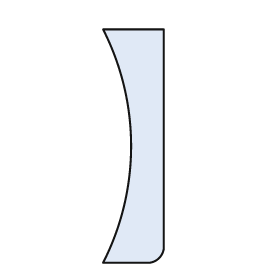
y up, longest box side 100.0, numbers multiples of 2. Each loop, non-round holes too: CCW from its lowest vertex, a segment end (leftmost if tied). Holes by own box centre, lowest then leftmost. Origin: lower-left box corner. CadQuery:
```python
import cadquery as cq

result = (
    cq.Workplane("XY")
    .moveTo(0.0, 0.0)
    .lineTo(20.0, 0.0)
    .threePointArc((24.0, 2.0), (26.0, 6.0))
    .lineTo(26.0, 100.0)
    .lineTo(0.0, 100.0)
    .threePointArc((12.0, 50.0), (0.0, 0.0))
    .close()
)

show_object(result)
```